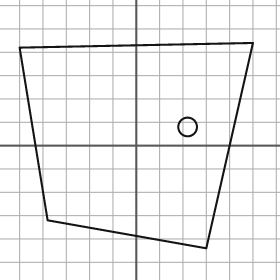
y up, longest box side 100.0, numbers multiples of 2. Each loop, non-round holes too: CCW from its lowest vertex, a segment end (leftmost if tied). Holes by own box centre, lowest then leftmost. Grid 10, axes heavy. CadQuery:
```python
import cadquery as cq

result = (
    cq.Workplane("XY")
    .moveTo(30.0, -44.0)
    .lineTo(50.0, 44.0)
    .lineTo(-50.0, 42.0)
    .lineTo(-38.0, -32.0)
    .close()
    .moveTo(22.0, 8.0)
    .circle(4.0)
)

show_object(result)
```